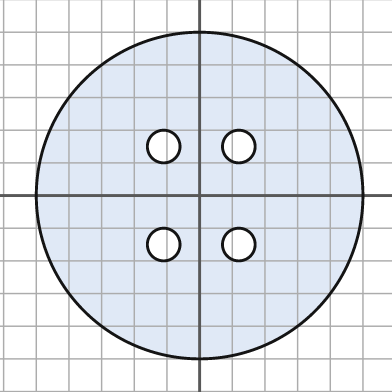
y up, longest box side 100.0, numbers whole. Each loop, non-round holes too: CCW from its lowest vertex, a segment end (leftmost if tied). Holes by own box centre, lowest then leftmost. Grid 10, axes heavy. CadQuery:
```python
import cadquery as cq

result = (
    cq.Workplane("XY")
    .moveTo(0.0, 0.0)
    .circle(50.0)
    .moveTo(-11.0, -15.0)
    .circle(5.0)
    .moveTo(12.0, -15.0)
    .circle(5.0)
    .moveTo(-11.0, 15.0)
    .circle(5.0)
    .moveTo(12.0, 15.0)
    .circle(5.0)
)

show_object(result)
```